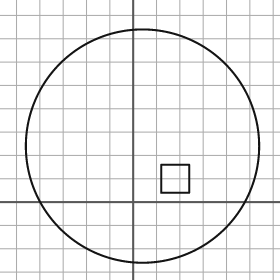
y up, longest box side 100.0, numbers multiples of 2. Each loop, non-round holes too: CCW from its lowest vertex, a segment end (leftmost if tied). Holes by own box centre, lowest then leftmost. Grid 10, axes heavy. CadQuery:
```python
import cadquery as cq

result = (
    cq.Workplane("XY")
    .moveTo(4.0, 24.0)
    .circle(50.0)
    .moveTo(12.0, 4.0)
    .lineTo(24.0, 4.0)
    .lineTo(24.0, 16.0)
    .lineTo(12.0, 16.0)
    .close()
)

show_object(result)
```